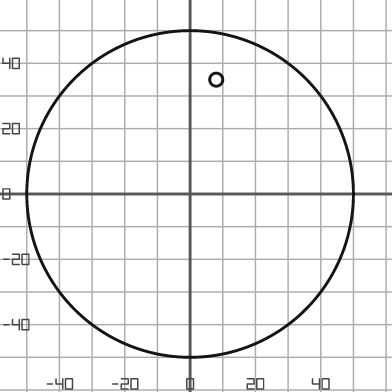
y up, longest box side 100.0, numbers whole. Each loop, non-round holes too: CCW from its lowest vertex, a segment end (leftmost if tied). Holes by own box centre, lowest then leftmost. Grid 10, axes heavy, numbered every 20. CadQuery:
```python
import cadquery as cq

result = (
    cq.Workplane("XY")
    .moveTo(0.0, 0.0)
    .circle(50.0)
    .moveTo(8.0, 35.0)
    .circle(2.0)
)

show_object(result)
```